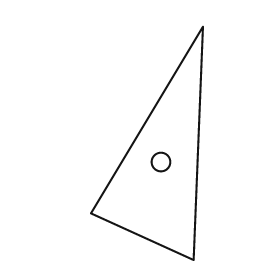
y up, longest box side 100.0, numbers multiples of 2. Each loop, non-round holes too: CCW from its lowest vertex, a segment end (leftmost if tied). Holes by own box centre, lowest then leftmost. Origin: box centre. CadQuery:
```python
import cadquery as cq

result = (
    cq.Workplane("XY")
    .moveTo(20.0, -50.0)
    .lineTo(24.0, 50.0)
    .lineTo(-24.0, -30.0)
    .close()
    .moveTo(6.0, -8.0)
    .circle(4.0)
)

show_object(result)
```